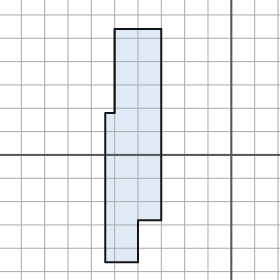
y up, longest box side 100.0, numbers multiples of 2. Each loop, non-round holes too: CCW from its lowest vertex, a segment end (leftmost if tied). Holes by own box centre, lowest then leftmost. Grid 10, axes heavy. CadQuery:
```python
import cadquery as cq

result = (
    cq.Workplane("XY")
    .moveTo(-54.0, -46.0)
    .lineTo(-40.0, -46.0)
    .lineTo(-40.0, -28.0)
    .lineTo(-30.0, -28.0)
    .lineTo(-30.0, 54.0)
    .lineTo(-50.0, 54.0)
    .lineTo(-50.0, 18.0)
    .lineTo(-54.0, 18.0)
    .close()
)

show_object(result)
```